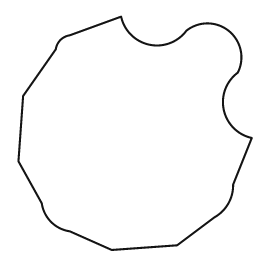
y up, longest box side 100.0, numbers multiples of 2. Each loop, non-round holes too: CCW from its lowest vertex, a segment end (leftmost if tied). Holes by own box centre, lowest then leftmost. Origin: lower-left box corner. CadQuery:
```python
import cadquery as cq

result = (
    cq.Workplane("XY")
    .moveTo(40.0, 0.0)
    .lineTo(68.0, 2.0)
    .lineTo(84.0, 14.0)
    .threePointArc((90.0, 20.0), (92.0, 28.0))
    .lineTo(100.0, 48.0)
    .threePointArc((88.0, 60.0), (94.0, 76.0))
    .threePointArc((90.0, 94.0), (72.0, 94.0))
    .threePointArc((56.0, 88.0), (44.0, 100.0))
    .lineTo(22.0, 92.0)
    .threePointArc((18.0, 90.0), (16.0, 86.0))
    .lineTo(2.0, 66.0)
    .lineTo(0.0, 38.0)
    .lineTo(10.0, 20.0)
    .threePointArc((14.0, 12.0), (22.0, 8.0))
    .close()
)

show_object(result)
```